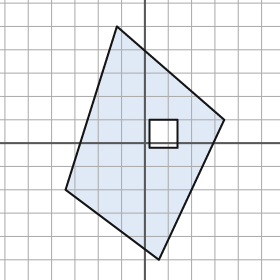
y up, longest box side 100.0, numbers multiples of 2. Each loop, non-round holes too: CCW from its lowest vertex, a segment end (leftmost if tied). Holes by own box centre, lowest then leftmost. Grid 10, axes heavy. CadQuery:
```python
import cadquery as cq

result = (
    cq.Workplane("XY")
    .moveTo(6.0, -50.0)
    .lineTo(34.0, 10.0)
    .lineTo(-12.0, 50.0)
    .lineTo(-34.0, -20.0)
    .close()
    .moveTo(2.0, -2.0)
    .lineTo(14.0, -2.0)
    .lineTo(14.0, 10.0)
    .lineTo(2.0, 10.0)
    .close()
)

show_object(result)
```